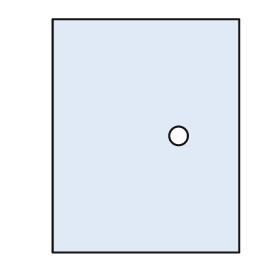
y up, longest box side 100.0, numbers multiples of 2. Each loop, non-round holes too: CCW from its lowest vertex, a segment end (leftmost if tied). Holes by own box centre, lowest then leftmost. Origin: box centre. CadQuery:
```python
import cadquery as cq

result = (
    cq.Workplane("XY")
    .moveTo(-40.0, -50.0)
    .lineTo(40.0, -50.0)
    .lineTo(40.0, 50.0)
    .lineTo(-40.0, 50.0)
    .close()
    .moveTo(14.0, 0.0)
    .circle(4.0)
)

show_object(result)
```